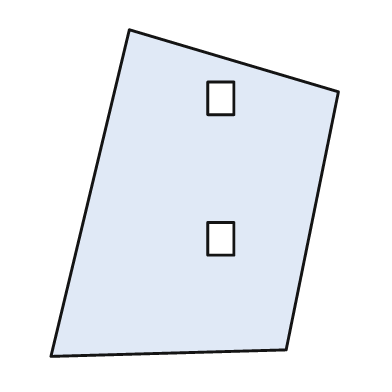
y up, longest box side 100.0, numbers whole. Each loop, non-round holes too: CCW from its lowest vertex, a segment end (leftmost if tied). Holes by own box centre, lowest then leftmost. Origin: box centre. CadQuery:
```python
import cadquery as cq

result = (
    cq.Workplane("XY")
    .moveTo(-44.0, -50.0)
    .lineTo(28.0, -48.0)
    .lineTo(44.0, 31.0)
    .lineTo(-20.0, 50.0)
    .close()
    .moveTo(4.0, -19.0)
    .lineTo(12.0, -19.0)
    .lineTo(12.0, -9.0)
    .lineTo(4.0, -9.0)
    .close()
    .moveTo(4.0, 24.0)
    .lineTo(12.0, 24.0)
    .lineTo(12.0, 34.0)
    .lineTo(4.0, 34.0)
    .close()
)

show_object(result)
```